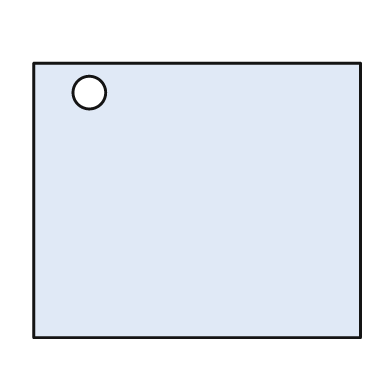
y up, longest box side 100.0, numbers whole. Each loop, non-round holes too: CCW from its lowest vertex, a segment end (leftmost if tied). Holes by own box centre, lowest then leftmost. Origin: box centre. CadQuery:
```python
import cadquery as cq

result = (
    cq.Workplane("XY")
    .moveTo(-50.0, -42.0)
    .lineTo(50.0, -42.0)
    .lineTo(50.0, 42.0)
    .lineTo(-50.0, 42.0)
    .close()
    .moveTo(-33.0, 33.0)
    .circle(5.0)
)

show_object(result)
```